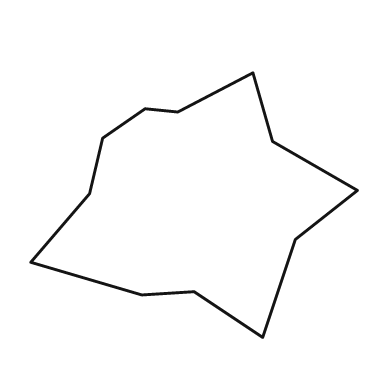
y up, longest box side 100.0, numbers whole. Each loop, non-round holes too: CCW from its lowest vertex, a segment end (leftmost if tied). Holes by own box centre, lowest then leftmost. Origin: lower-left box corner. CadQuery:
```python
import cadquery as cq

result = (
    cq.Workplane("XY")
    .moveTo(71.0, 0.0)
    .lineTo(81.0, 30.0)
    .lineTo(100.0, 45.0)
    .lineTo(74.0, 60.0)
    .lineTo(68.0, 81.0)
    .lineTo(45.0, 69.0)
    .lineTo(35.0, 70.0)
    .lineTo(22.0, 61.0)
    .lineTo(18.0, 44.0)
    .lineTo(0.0, 23.0)
    .lineTo(34.0, 13.0)
    .lineTo(50.0, 14.0)
    .close()
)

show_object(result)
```